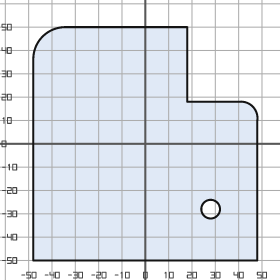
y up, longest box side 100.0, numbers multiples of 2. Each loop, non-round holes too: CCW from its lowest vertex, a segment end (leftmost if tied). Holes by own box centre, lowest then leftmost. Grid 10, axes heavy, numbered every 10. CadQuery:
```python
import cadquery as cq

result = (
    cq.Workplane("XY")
    .moveTo(-48.0, -50.0)
    .lineTo(48.0, -50.0)
    .lineTo(48.0, 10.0)
    .threePointArc((46.0, 16.0), (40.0, 18.0))
    .lineTo(18.0, 18.0)
    .lineTo(18.0, 50.0)
    .lineTo(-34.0, 50.0)
    .threePointArc((-44.0, 46.0), (-48.0, 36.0))
    .close()
    .moveTo(28.0, -28.0)
    .circle(4.0)
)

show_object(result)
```